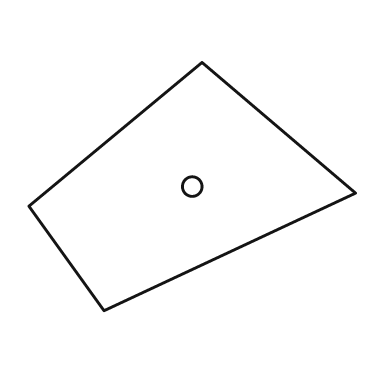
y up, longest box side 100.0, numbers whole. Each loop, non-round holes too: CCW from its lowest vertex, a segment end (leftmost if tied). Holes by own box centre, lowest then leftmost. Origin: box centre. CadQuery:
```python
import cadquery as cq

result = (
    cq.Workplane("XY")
    .moveTo(-27.0, -38.0)
    .lineTo(50.0, -2.0)
    .lineTo(3.0, 38.0)
    .lineTo(-50.0, -6.0)
    .close()
    .moveTo(0.0, 0.0)
    .circle(3.0)
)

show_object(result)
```